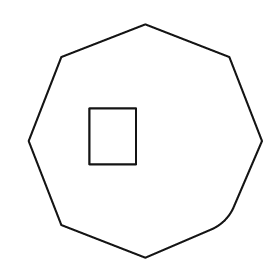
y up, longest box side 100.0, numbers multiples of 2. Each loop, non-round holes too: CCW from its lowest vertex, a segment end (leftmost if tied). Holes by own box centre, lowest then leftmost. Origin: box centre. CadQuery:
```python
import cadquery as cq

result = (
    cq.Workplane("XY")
    .moveTo(0.0, -50.0)
    .lineTo(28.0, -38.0)
    .threePointArc((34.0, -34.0), (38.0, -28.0))
    .lineTo(50.0, 0.0)
    .lineTo(36.0, 36.0)
    .lineTo(0.0, 50.0)
    .lineTo(-36.0, 36.0)
    .lineTo(-50.0, 0.0)
    .lineTo(-36.0, -36.0)
    .close()
    .moveTo(-24.0, -10.0)
    .lineTo(-4.0, -10.0)
    .lineTo(-4.0, 14.0)
    .lineTo(-24.0, 14.0)
    .close()
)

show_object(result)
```